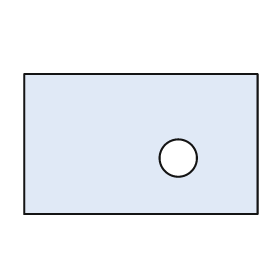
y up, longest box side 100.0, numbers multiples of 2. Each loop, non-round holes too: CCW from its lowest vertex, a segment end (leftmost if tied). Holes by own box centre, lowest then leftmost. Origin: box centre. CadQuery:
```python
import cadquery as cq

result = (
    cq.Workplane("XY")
    .moveTo(-50.0, -30.0)
    .lineTo(50.0, -30.0)
    .lineTo(50.0, 30.0)
    .lineTo(-50.0, 30.0)
    .close()
    .moveTo(16.0, -6.0)
    .circle(8.0)
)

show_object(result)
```